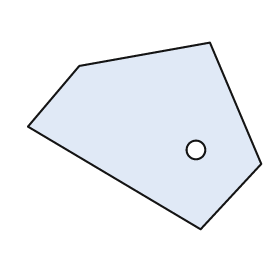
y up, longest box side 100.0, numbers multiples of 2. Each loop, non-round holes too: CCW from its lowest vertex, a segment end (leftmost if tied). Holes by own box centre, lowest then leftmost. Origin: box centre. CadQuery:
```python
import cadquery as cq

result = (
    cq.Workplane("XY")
    .moveTo(24.0, -40.0)
    .lineTo(50.0, -12.0)
    .lineTo(28.0, 40.0)
    .lineTo(-28.0, 30.0)
    .lineTo(-50.0, 4.0)
    .close()
    .moveTo(22.0, -6.0)
    .circle(4.0)
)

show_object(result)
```